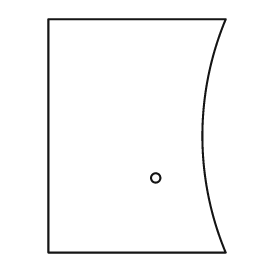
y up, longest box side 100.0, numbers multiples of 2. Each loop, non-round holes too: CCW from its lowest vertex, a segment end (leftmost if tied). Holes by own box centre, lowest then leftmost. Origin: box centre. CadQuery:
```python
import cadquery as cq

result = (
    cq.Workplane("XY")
    .moveTo(-38.0, -50.0)
    .lineTo(38.0, -50.0)
    .threePointArc((28.0, 0.0), (38.0, 50.0))
    .lineTo(-38.0, 50.0)
    .close()
    .moveTo(8.0, -18.0)
    .circle(2.0)
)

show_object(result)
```